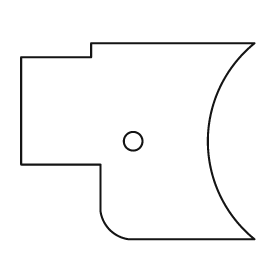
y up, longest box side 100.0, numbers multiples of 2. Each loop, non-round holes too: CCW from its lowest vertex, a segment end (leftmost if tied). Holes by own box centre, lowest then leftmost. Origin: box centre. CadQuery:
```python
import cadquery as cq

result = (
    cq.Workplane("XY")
    .moveTo(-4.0, -42.0)
    .lineTo(50.0, -42.0)
    .threePointArc((30.0, 0.0), (50.0, 42.0))
    .lineTo(-20.0, 42.0)
    .lineTo(-20.0, 36.0)
    .lineTo(-50.0, 36.0)
    .lineTo(-50.0, -10.0)
    .lineTo(-16.0, -10.0)
    .lineTo(-16.0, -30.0)
    .threePointArc((-12.0, -38.0), (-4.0, -42.0))
    .close()
    .moveTo(-2.0, 0.0)
    .circle(4.0)
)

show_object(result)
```